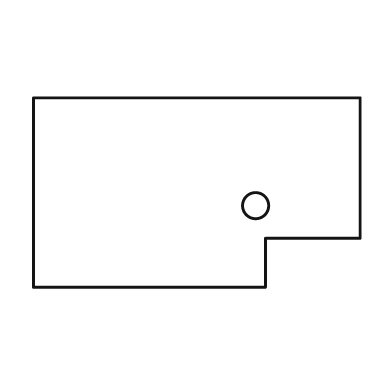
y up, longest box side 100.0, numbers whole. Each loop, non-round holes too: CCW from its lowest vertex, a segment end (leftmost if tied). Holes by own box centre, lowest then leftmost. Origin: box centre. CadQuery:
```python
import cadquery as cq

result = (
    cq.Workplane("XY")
    .moveTo(-50.0, -29.0)
    .lineTo(21.0, -29.0)
    .lineTo(21.0, -14.0)
    .lineTo(50.0, -14.0)
    .lineTo(50.0, 29.0)
    .lineTo(-50.0, 29.0)
    .close()
    .moveTo(18.0, -4.0)
    .circle(4.0)
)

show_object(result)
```